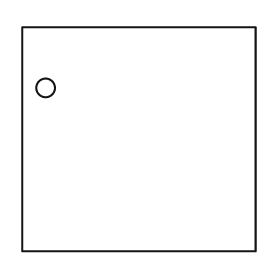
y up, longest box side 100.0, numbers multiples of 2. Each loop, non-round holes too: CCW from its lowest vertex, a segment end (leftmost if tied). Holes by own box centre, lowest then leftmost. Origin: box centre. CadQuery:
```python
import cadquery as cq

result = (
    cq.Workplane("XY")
    .moveTo(-50.0, -48.0)
    .lineTo(50.0, -48.0)
    .lineTo(50.0, 48.0)
    .lineTo(-50.0, 48.0)
    .close()
    .moveTo(-40.0, 22.0)
    .circle(4.0)
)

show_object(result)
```